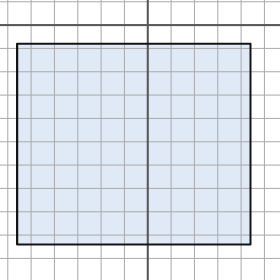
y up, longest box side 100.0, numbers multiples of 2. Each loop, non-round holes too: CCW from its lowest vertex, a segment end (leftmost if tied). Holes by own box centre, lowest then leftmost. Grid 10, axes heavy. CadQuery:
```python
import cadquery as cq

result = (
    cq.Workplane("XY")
    .moveTo(-56.0, -94.0)
    .lineTo(44.0, -94.0)
    .lineTo(44.0, -8.0)
    .lineTo(-56.0, -8.0)
    .close()
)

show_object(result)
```